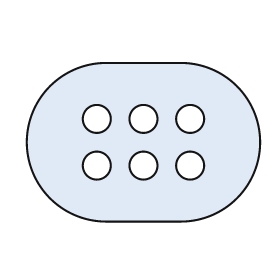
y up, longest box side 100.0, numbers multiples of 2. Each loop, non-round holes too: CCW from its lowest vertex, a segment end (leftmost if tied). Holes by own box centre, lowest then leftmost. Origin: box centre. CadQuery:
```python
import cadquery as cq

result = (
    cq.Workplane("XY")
    .moveTo(-16.0, -34.0)
    .lineTo(16.0, -34.0)
    .threePointArc((50.0, 0.0), (16.0, 34.0))
    .lineTo(-16.0, 34.0)
    .threePointArc((-50.0, 0.0), (-16.0, -34.0))
    .close()
    .moveTo(-20.0, -10.0)
    .circle(6.0)
    .moveTo(0.0, -10.0)
    .circle(6.0)
    .moveTo(20.0, -10.0)
    .circle(6.0)
    .moveTo(-20.0, 10.0)
    .circle(6.0)
    .moveTo(0.0, 10.0)
    .circle(6.0)
    .moveTo(20.0, 10.0)
    .circle(6.0)
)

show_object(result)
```